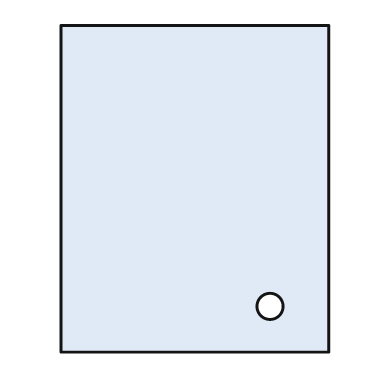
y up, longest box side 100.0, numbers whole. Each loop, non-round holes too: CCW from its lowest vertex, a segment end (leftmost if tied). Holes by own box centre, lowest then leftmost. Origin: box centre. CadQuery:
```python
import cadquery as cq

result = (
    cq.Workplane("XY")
    .moveTo(-41.0, -50.0)
    .lineTo(41.0, -50.0)
    .lineTo(41.0, 50.0)
    .lineTo(-41.0, 50.0)
    .close()
    .moveTo(23.0, -36.0)
    .circle(4.0)
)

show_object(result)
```